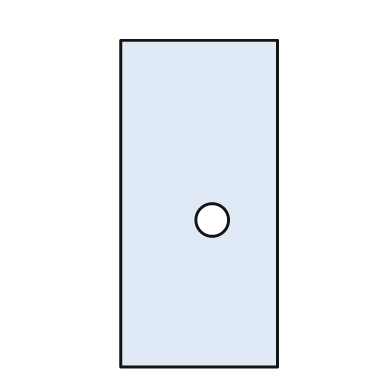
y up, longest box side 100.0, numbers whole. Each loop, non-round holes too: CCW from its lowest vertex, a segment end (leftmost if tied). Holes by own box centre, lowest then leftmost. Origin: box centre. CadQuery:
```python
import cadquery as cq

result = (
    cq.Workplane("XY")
    .moveTo(-24.0, -50.0)
    .lineTo(24.0, -50.0)
    .lineTo(24.0, 50.0)
    .lineTo(-24.0, 50.0)
    .close()
    .moveTo(4.0, -5.0)
    .circle(5.0)
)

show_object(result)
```